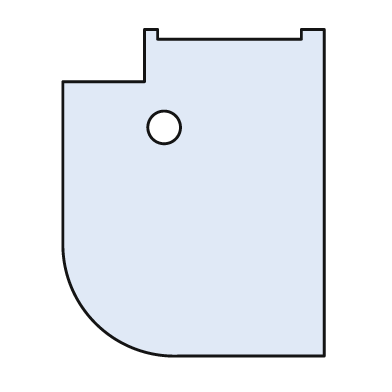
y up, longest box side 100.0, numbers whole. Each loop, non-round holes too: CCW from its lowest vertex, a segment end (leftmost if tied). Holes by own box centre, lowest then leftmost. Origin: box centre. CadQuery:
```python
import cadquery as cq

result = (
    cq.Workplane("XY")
    .moveTo(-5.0, -50.0)
    .lineTo(40.0, -50.0)
    .lineTo(40.0, 50.0)
    .lineTo(33.0, 50.0)
    .lineTo(33.0, 47.0)
    .lineTo(-11.0, 47.0)
    .lineTo(-11.0, 50.0)
    .lineTo(-15.0, 50.0)
    .lineTo(-15.0, 34.0)
    .lineTo(-40.0, 34.0)
    .lineTo(-40.0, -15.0)
    .threePointArc((-30.0, -40.0), (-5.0, -50.0))
    .close()
    .moveTo(-9.0, 20.0)
    .circle(5.0)
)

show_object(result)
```